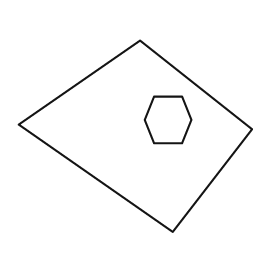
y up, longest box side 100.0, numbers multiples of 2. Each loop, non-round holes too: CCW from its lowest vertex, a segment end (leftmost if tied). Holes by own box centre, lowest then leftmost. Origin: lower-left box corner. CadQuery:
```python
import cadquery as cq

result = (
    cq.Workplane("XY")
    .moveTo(66.0, 0.0)
    .lineTo(100.0, 44.0)
    .lineTo(52.0, 82.0)
    .lineTo(0.0, 46.0)
    .close()
    .moveTo(58.0, 38.0)
    .lineTo(70.0, 38.0)
    .lineTo(74.0, 48.0)
    .lineTo(70.0, 58.0)
    .lineTo(58.0, 58.0)
    .lineTo(54.0, 48.0)
    .close()
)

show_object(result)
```